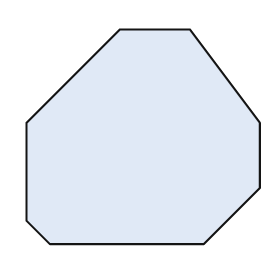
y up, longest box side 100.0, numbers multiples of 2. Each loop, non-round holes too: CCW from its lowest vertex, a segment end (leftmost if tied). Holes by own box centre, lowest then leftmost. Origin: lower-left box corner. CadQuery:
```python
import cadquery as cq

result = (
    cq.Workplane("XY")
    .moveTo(10.0, 0.0)
    .lineTo(76.0, 0.0)
    .lineTo(100.0, 24.0)
    .lineTo(100.0, 52.0)
    .lineTo(70.0, 92.0)
    .lineTo(40.0, 92.0)
    .lineTo(0.0, 52.0)
    .lineTo(0.0, 10.0)
    .close()
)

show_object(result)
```